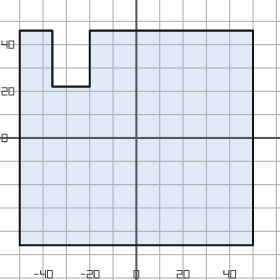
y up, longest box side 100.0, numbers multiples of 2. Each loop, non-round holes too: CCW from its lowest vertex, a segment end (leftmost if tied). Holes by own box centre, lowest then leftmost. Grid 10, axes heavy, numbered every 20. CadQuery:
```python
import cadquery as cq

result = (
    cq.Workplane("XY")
    .moveTo(-50.0, -46.0)
    .lineTo(50.0, -46.0)
    .lineTo(50.0, 46.0)
    .lineTo(-20.0, 46.0)
    .lineTo(-20.0, 22.0)
    .lineTo(-36.0, 22.0)
    .lineTo(-36.0, 46.0)
    .lineTo(-50.0, 46.0)
    .close()
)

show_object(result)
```